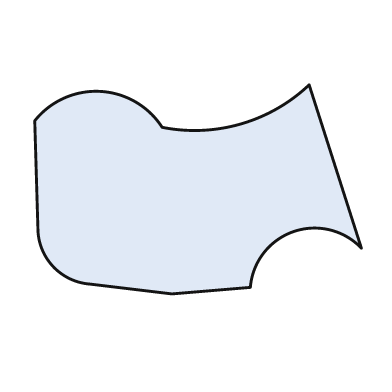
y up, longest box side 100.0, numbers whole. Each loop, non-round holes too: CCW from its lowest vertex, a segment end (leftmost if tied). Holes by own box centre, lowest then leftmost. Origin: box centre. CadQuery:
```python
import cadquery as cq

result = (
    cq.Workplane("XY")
    .moveTo(-8.0, -32.0)
    .lineTo(16.0, -30.0)
    .threePointArc((29.0, -13.0), (50.0, -18.0))
    .lineTo(34.0, 32.0)
    .threePointArc((13.0, 20.0), (-11.0, 19.0))
    .threePointArc((-30.0, 30.0), (-50.0, 21.0))
    .lineTo(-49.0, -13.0)
    .threePointArc((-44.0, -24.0), (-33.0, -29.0))
    .close()
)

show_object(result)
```